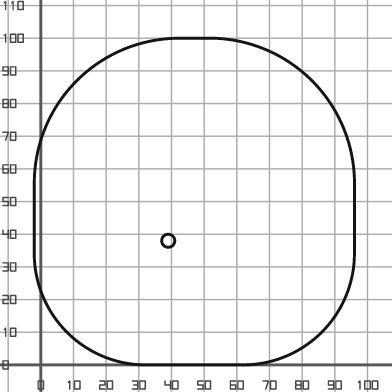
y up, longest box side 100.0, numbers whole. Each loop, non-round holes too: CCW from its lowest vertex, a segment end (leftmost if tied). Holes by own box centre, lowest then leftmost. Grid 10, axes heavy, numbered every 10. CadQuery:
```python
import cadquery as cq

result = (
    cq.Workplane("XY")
    .moveTo(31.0, 0.0)
    .lineTo(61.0, 0.0)
    .threePointArc((86.0, 10.0), (96.0, 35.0))
    .lineTo(96.0, 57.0)
    .threePointArc((83.0, 87.0), (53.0, 100.0))
    .lineTo(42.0, 100.0)
    .threePointArc((11.0, 87.0), (-2.0, 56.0))
    .lineTo(-2.0, 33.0)
    .threePointArc((8.0, 10.0), (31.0, 0.0))
    .close()
    .moveTo(39.0, 38.0)
    .circle(2.0)
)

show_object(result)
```